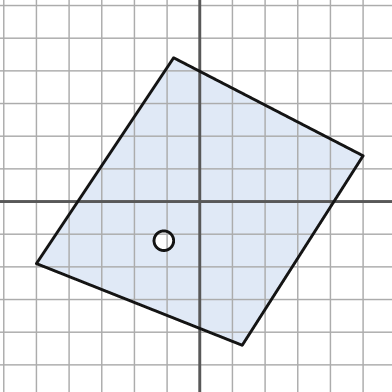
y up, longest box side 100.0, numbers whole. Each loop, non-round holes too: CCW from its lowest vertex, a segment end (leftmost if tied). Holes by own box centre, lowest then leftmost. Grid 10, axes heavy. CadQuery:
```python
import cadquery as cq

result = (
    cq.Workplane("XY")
    .moveTo(13.0, -44.0)
    .lineTo(50.0, 14.0)
    .lineTo(-8.0, 44.0)
    .lineTo(-50.0, -19.0)
    .close()
    .moveTo(-11.0, -12.0)
    .circle(3.0)
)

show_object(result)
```